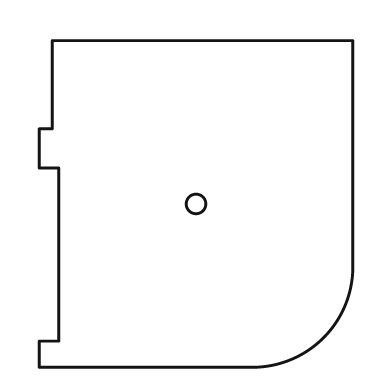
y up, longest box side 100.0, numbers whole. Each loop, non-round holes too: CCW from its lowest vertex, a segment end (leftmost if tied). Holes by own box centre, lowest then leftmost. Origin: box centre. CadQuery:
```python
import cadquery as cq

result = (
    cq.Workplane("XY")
    .moveTo(-48.0, -50.0)
    .lineTo(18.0, -50.0)
    .threePointArc((39.0, -41.0), (48.0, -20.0))
    .lineTo(48.0, 50.0)
    .lineTo(-44.0, 50.0)
    .lineTo(-44.0, 23.0)
    .lineTo(-48.0, 23.0)
    .lineTo(-48.0, 11.0)
    .lineTo(-42.0, 11.0)
    .lineTo(-42.0, -42.0)
    .lineTo(-48.0, -42.0)
    .close()
    .moveTo(0.0, 0.0)
    .circle(3.0)
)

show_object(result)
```